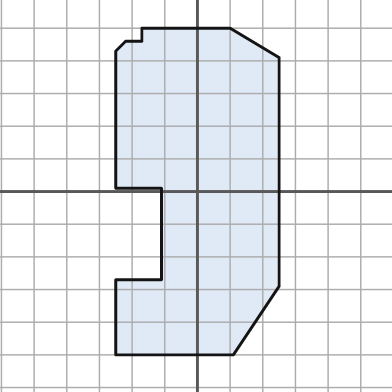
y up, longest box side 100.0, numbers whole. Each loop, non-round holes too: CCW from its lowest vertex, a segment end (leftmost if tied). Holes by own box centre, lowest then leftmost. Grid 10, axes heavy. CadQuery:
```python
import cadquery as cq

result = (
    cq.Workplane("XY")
    .moveTo(-25.0, -50.0)
    .lineTo(11.0, -50.0)
    .lineTo(25.0, -29.0)
    .lineTo(25.0, 41.0)
    .lineTo(10.0, 50.0)
    .lineTo(-17.0, 50.0)
    .lineTo(-17.0, 46.0)
    .lineTo(-22.0, 46.0)
    .lineTo(-25.0, 43.0)
    .lineTo(-25.0, 1.0)
    .lineTo(-11.0, 1.0)
    .lineTo(-11.0, -27.0)
    .lineTo(-25.0, -27.0)
    .close()
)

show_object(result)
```